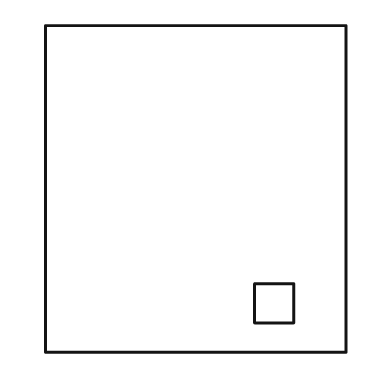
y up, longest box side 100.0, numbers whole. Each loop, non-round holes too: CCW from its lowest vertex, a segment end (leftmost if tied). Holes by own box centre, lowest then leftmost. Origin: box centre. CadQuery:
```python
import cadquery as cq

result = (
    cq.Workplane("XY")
    .moveTo(-46.0, -50.0)
    .lineTo(46.0, -50.0)
    .lineTo(46.0, 50.0)
    .lineTo(-46.0, 50.0)
    .close()
    .moveTo(18.0, -41.0)
    .lineTo(30.0, -41.0)
    .lineTo(30.0, -29.0)
    .lineTo(18.0, -29.0)
    .close()
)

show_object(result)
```